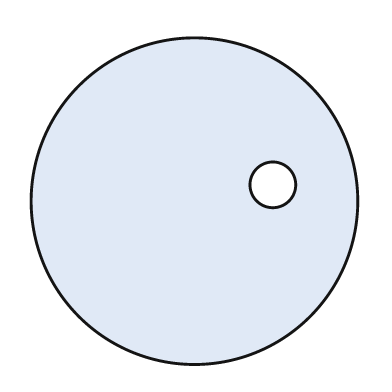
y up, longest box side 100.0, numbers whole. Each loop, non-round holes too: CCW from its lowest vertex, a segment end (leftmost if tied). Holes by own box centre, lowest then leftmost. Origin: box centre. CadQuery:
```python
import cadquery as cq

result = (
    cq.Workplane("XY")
    .moveTo(0.0, 0.0)
    .circle(50.0)
    .moveTo(24.0, 5.0)
    .circle(7.0)
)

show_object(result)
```